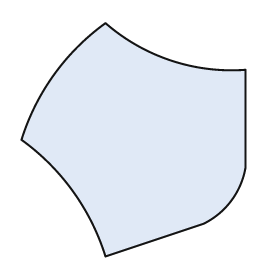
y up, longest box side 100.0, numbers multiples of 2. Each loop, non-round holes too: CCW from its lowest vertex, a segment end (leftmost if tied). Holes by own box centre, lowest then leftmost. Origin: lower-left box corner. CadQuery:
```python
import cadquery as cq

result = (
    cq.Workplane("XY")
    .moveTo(36.0, 0.0)
    .lineTo(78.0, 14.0)
    .threePointArc((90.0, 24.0), (96.0, 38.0))
    .lineTo(96.0, 80.0)
    .threePointArc((64.0, 84.0), (36.0, 100.0))
    .threePointArc((14.0, 78.0), (0.0, 50.0))
    .threePointArc((22.0, 28.0), (36.0, 0.0))
    .close()
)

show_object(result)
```